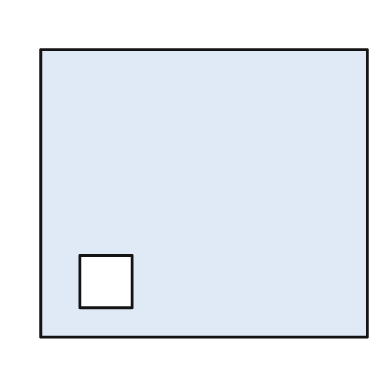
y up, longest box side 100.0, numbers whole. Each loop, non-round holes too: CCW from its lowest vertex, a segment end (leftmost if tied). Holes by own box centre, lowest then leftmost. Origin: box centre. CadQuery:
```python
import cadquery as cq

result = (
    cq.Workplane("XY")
    .moveTo(-50.0, -44.0)
    .lineTo(50.0, -44.0)
    .lineTo(50.0, 44.0)
    .lineTo(-50.0, 44.0)
    .close()
    .moveTo(-38.0, -35.0)
    .lineTo(-22.0, -35.0)
    .lineTo(-22.0, -19.0)
    .lineTo(-38.0, -19.0)
    .close()
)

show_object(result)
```